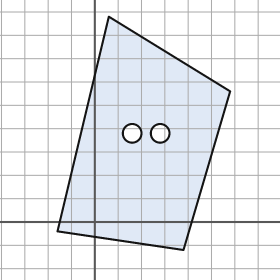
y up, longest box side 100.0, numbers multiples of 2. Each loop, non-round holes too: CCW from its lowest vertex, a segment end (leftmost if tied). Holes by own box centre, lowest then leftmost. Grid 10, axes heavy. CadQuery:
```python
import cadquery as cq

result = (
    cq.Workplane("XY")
    .moveTo(38.0, -12.0)
    .lineTo(58.0, 56.0)
    .lineTo(6.0, 88.0)
    .lineTo(-16.0, -4.0)
    .close()
    .moveTo(16.0, 38.0)
    .circle(4.0)
    .moveTo(28.0, 38.0)
    .circle(4.0)
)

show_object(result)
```